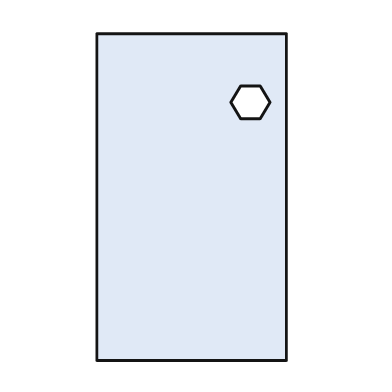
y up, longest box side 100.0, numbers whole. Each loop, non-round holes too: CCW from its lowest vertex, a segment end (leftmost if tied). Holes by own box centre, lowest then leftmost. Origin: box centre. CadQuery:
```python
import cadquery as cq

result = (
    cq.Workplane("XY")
    .moveTo(-29.0, -50.0)
    .lineTo(29.0, -50.0)
    .lineTo(29.0, 50.0)
    .lineTo(-29.0, 50.0)
    .close()
    .moveTo(15.0, 24.0)
    .lineTo(21.0, 24.0)
    .lineTo(24.0, 29.0)
    .lineTo(21.0, 34.0)
    .lineTo(15.0, 34.0)
    .lineTo(12.0, 29.0)
    .close()
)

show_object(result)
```